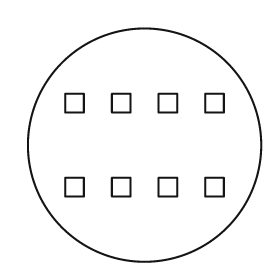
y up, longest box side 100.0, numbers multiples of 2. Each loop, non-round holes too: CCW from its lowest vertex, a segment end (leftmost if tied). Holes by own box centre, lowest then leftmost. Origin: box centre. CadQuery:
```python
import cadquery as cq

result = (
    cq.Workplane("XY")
    .moveTo(0.0, 0.0)
    .circle(50.0)
    .moveTo(-34.0, -22.0)
    .lineTo(-26.0, -22.0)
    .lineTo(-26.0, -14.0)
    .lineTo(-34.0, -14.0)
    .close()
    .moveTo(-14.0, -22.0)
    .lineTo(-6.0, -22.0)
    .lineTo(-6.0, -14.0)
    .lineTo(-14.0, -14.0)
    .close()
    .moveTo(6.0, -22.0)
    .lineTo(14.0, -22.0)
    .lineTo(14.0, -14.0)
    .lineTo(6.0, -14.0)
    .close()
    .moveTo(26.0, -22.0)
    .lineTo(34.0, -22.0)
    .lineTo(34.0, -14.0)
    .lineTo(26.0, -14.0)
    .close()
    .moveTo(-34.0, 14.0)
    .lineTo(-26.0, 14.0)
    .lineTo(-26.0, 22.0)
    .lineTo(-34.0, 22.0)
    .close()
    .moveTo(-14.0, 14.0)
    .lineTo(-6.0, 14.0)
    .lineTo(-6.0, 22.0)
    .lineTo(-14.0, 22.0)
    .close()
    .moveTo(6.0, 14.0)
    .lineTo(14.0, 14.0)
    .lineTo(14.0, 22.0)
    .lineTo(6.0, 22.0)
    .close()
    .moveTo(26.0, 14.0)
    .lineTo(34.0, 14.0)
    .lineTo(34.0, 22.0)
    .lineTo(26.0, 22.0)
    .close()
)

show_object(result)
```